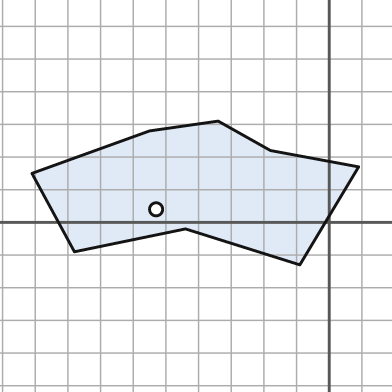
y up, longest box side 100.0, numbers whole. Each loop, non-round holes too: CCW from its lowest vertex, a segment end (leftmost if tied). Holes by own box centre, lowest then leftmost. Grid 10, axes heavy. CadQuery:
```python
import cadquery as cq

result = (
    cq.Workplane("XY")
    .moveTo(-9.0, -13.0)
    .lineTo(9.0, 17.0)
    .lineTo(-18.0, 22.0)
    .lineTo(-34.0, 31.0)
    .lineTo(-55.0, 28.0)
    .lineTo(-91.0, 15.0)
    .lineTo(-78.0, -9.0)
    .lineTo(-44.0, -2.0)
    .close()
    .moveTo(-53.0, 4.0)
    .circle(2.0)
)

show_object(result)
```